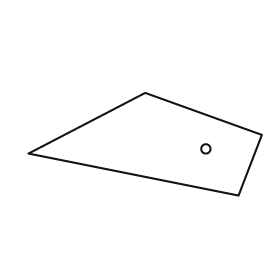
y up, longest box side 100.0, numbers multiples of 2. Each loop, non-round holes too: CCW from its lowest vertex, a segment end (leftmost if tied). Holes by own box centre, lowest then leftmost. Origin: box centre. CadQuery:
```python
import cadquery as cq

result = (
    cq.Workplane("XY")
    .moveTo(40.0, -22.0)
    .lineTo(50.0, 4.0)
    .lineTo(0.0, 22.0)
    .lineTo(-50.0, -4.0)
    .close()
    .moveTo(26.0, -2.0)
    .circle(2.0)
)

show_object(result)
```